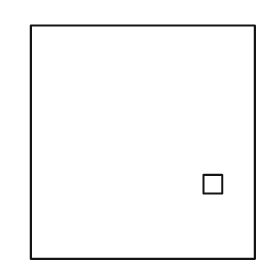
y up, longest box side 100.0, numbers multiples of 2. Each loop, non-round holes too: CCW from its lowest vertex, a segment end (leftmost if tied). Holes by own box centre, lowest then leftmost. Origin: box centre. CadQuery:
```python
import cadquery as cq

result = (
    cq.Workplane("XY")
    .moveTo(-48.0, -50.0)
    .lineTo(48.0, -50.0)
    .lineTo(48.0, 50.0)
    .lineTo(-48.0, 50.0)
    .close()
    .moveTo(26.0, -22.0)
    .lineTo(34.0, -22.0)
    .lineTo(34.0, -14.0)
    .lineTo(26.0, -14.0)
    .close()
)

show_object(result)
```